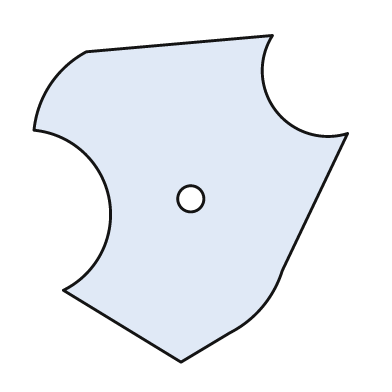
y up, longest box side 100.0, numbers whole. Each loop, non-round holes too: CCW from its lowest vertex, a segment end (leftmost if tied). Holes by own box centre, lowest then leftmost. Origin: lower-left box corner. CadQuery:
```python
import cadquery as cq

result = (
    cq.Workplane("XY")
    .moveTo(45.0, 0.0)
    .lineTo(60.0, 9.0)
    .threePointArc((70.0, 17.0), (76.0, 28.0))
    .lineTo(96.0, 70.0)
    .threePointArc((74.0, 77.0), (73.0, 100.0))
    .lineTo(16.0, 95.0)
    .threePointArc((5.0, 85.0), (0.0, 71.0))
    .threePointArc((23.0, 50.0), (9.0, 22.0))
    .close()
    .moveTo(48.0, 50.0)
    .circle(4.0)
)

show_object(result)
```